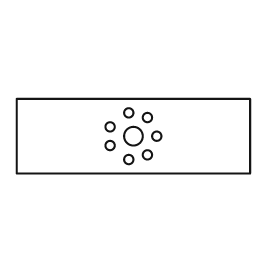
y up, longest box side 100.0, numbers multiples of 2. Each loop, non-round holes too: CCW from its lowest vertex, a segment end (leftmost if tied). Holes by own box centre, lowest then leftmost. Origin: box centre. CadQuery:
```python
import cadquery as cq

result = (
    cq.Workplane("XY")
    .moveTo(-50.0, -16.0)
    .lineTo(50.0, -16.0)
    .lineTo(50.0, 16.0)
    .lineTo(-50.0, 16.0)
    .close()
    .moveTo(-2.0, -10.0)
    .circle(2.0)
    .moveTo(6.0, -8.0)
    .circle(2.0)
    .moveTo(-10.0, -4.0)
    .circle(2.0)
    .moveTo(0.0, 0.0)
    .circle(4.0)
    .moveTo(10.0, 0.0)
    .circle(2.0)
    .moveTo(-10.0, 4.0)
    .circle(2.0)
    .moveTo(6.0, 8.0)
    .circle(2.0)
    .moveTo(-2.0, 10.0)
    .circle(2.0)
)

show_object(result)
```